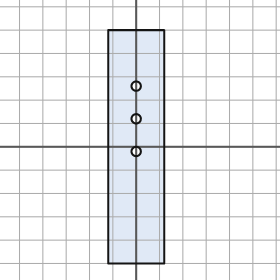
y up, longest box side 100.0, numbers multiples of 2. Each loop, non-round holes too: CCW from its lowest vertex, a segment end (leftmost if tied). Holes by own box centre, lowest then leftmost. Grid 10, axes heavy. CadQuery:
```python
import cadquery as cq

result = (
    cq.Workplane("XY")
    .moveTo(-12.0, -50.0)
    .lineTo(12.0, -50.0)
    .lineTo(12.0, 50.0)
    .lineTo(-12.0, 50.0)
    .close()
    .moveTo(0.0, -2.0)
    .circle(2.0)
    .moveTo(0.0, 12.0)
    .circle(2.0)
    .moveTo(0.0, 26.0)
    .circle(2.0)
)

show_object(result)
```